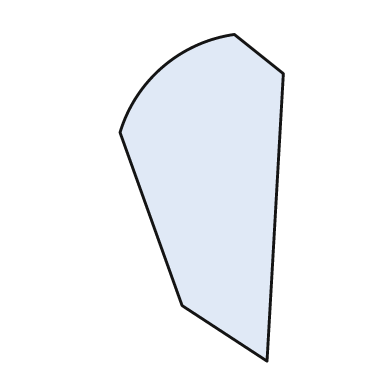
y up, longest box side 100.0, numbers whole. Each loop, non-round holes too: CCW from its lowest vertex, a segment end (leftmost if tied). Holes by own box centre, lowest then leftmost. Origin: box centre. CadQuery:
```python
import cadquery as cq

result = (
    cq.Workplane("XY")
    .moveTo(20.0, -50.0)
    .lineTo(25.0, 38.0)
    .lineTo(10.0, 50.0)
    .threePointArc((-12.0, 40.0), (-25.0, 20.0))
    .lineTo(-6.0, -33.0)
    .close()
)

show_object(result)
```